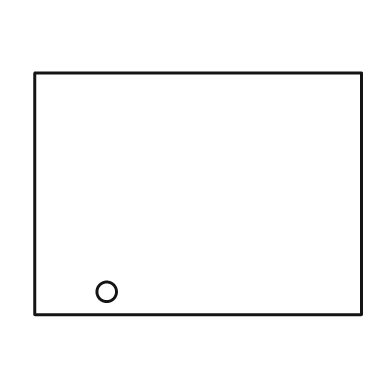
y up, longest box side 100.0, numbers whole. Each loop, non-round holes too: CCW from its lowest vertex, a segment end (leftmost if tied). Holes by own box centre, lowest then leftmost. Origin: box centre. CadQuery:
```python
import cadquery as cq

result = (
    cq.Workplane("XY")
    .moveTo(-50.0, -37.0)
    .lineTo(50.0, -37.0)
    .lineTo(50.0, 37.0)
    .lineTo(-50.0, 37.0)
    .close()
    .moveTo(-28.0, -30.0)
    .circle(3.0)
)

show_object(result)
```